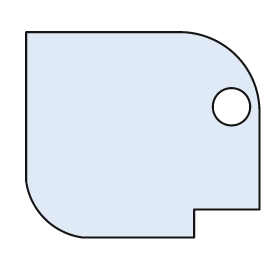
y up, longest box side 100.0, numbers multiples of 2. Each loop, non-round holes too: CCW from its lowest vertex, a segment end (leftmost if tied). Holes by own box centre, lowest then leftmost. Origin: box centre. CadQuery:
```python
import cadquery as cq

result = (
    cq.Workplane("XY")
    .moveTo(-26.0, -44.0)
    .lineTo(22.0, -44.0)
    .lineTo(22.0, -32.0)
    .lineTo(50.0, -32.0)
    .lineTo(50.0, 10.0)
    .threePointArc((40.0, 34.0), (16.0, 44.0))
    .lineTo(-50.0, 44.0)
    .lineTo(-50.0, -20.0)
    .threePointArc((-42.0, -36.0), (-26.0, -44.0))
    .close()
    .moveTo(38.0, 12.0)
    .circle(8.0)
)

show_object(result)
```